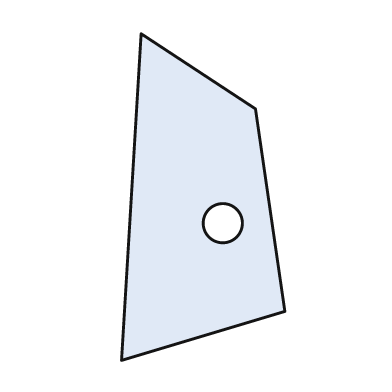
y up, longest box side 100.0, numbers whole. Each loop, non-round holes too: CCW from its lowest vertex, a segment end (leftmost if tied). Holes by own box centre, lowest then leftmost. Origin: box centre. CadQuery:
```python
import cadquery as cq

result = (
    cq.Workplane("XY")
    .moveTo(-25.0, -50.0)
    .lineTo(25.0, -35.0)
    .lineTo(16.0, 27.0)
    .lineTo(-19.0, 50.0)
    .close()
    .moveTo(6.0, -8.0)
    .circle(6.0)
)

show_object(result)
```